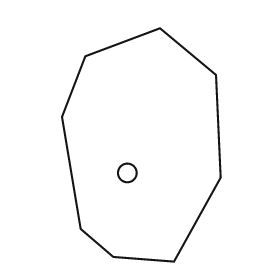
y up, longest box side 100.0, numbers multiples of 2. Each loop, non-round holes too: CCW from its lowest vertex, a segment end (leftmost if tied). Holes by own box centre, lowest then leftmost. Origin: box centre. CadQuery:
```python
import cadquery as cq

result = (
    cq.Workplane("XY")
    .moveTo(14.0, -50.0)
    .lineTo(34.0, -14.0)
    .lineTo(32.0, 30.0)
    .lineTo(8.0, 50.0)
    .lineTo(-24.0, 38.0)
    .lineTo(-34.0, 12.0)
    .lineTo(-26.0, -36.0)
    .lineTo(-12.0, -48.0)
    .close()
    .moveTo(-6.0, -12.0)
    .circle(4.0)
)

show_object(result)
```